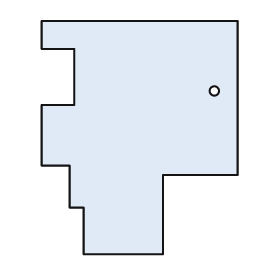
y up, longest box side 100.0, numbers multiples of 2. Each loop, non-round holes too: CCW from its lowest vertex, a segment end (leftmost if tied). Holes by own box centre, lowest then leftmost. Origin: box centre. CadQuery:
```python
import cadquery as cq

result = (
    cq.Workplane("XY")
    .moveTo(-24.0, -50.0)
    .lineTo(10.0, -50.0)
    .lineTo(10.0, -16.0)
    .lineTo(42.0, -16.0)
    .lineTo(42.0, 50.0)
    .lineTo(-42.0, 50.0)
    .lineTo(-42.0, 38.0)
    .lineTo(-28.0, 38.0)
    .lineTo(-28.0, 14.0)
    .lineTo(-42.0, 14.0)
    .lineTo(-42.0, -12.0)
    .lineTo(-30.0, -12.0)
    .lineTo(-30.0, -30.0)
    .lineTo(-24.0, -30.0)
    .close()
    .moveTo(32.0, 20.0)
    .circle(2.0)
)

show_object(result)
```